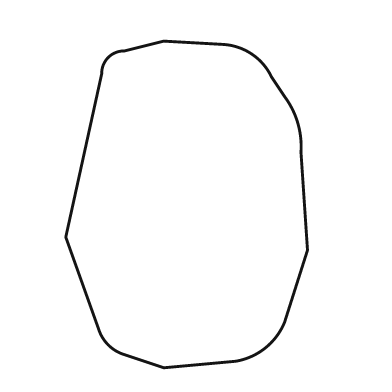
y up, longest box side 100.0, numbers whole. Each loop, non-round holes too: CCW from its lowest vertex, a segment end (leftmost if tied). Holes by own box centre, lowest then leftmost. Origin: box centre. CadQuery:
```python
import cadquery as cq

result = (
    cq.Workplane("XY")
    .moveTo(-7.0, -50.0)
    .lineTo(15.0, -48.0)
    .threePointArc((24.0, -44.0), (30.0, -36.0))
    .lineTo(37.0, -14.0)
    .lineTo(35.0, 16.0)
    .threePointArc((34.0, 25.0), (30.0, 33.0))
    .lineTo(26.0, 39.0)
    .threePointArc((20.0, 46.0), (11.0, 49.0))
    .lineTo(-7.0, 50.0)
    .lineTo(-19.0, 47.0)
    .threePointArc((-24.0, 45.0), (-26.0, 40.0))
    .lineTo(-37.0, -10.0)
    .lineTo(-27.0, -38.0)
    .threePointArc((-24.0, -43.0), (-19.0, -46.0))
    .close()
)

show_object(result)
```